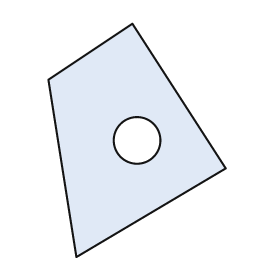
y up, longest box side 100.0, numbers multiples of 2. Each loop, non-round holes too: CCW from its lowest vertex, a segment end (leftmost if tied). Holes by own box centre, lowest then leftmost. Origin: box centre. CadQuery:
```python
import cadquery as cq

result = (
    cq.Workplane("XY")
    .moveTo(-26.0, -50.0)
    .lineTo(38.0, -12.0)
    .lineTo(-2.0, 50.0)
    .lineTo(-38.0, 26.0)
    .close()
    .moveTo(0.0, 0.0)
    .circle(10.0)
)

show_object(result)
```